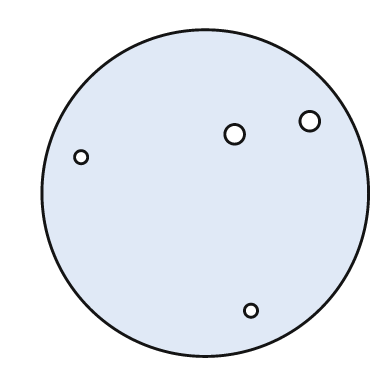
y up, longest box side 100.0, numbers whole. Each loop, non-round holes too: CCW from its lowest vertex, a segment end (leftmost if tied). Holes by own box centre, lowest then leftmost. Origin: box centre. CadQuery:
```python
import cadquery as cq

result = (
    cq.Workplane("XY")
    .moveTo(0.0, 0.0)
    .circle(50.0)
    .moveTo(14.0, -36.0)
    .circle(2.0)
    .moveTo(-38.0, 11.0)
    .circle(2.0)
    .moveTo(9.0, 18.0)
    .circle(3.0)
    .moveTo(32.0, 22.0)
    .circle(3.0)
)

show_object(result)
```